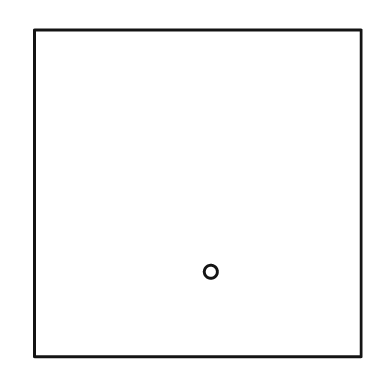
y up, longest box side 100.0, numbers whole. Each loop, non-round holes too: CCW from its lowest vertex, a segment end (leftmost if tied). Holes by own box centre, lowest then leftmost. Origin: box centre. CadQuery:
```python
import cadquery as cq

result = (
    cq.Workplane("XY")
    .moveTo(-50.0, -50.0)
    .lineTo(50.0, -50.0)
    .lineTo(50.0, 50.0)
    .lineTo(-50.0, 50.0)
    .close()
    .moveTo(4.0, -24.0)
    .circle(2.0)
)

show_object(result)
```